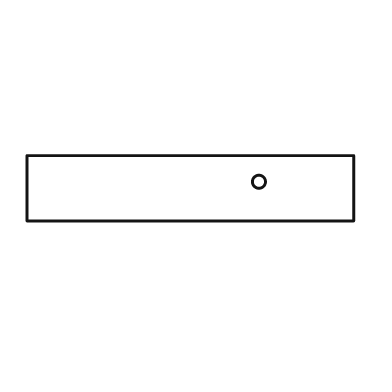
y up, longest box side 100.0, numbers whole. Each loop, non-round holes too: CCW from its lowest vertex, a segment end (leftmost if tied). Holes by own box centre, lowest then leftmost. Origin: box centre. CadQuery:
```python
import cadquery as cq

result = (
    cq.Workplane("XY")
    .moveTo(-50.0, -10.0)
    .lineTo(50.0, -10.0)
    .lineTo(50.0, 10.0)
    .lineTo(-50.0, 10.0)
    .close()
    .moveTo(21.0, 2.0)
    .circle(2.0)
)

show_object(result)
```